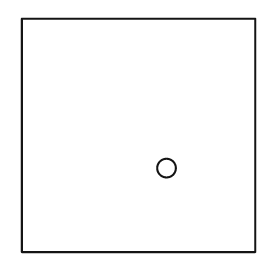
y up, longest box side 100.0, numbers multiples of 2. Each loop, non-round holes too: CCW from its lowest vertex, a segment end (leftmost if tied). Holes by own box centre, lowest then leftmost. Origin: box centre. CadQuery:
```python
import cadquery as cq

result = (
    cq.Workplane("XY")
    .moveTo(-50.0, -50.0)
    .lineTo(50.0, -50.0)
    .lineTo(50.0, 50.0)
    .lineTo(-50.0, 50.0)
    .close()
    .moveTo(12.0, -14.0)
    .circle(4.0)
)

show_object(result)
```